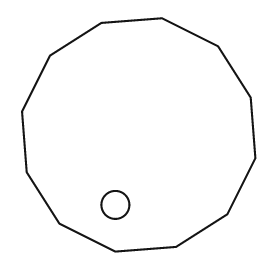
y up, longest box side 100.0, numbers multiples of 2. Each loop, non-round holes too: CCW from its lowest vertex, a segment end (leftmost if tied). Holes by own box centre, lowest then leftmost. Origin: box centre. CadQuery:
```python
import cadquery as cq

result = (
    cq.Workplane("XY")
    .moveTo(-10.0, -50.0)
    .lineTo(16.0, -48.0)
    .lineTo(38.0, -34.0)
    .lineTo(50.0, -10.0)
    .lineTo(48.0, 16.0)
    .lineTo(34.0, 38.0)
    .lineTo(10.0, 50.0)
    .lineTo(-16.0, 48.0)
    .lineTo(-38.0, 34.0)
    .lineTo(-50.0, 10.0)
    .lineTo(-48.0, -16.0)
    .lineTo(-34.0, -38.0)
    .close()
    .moveTo(-10.0, -30.0)
    .circle(6.0)
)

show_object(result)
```